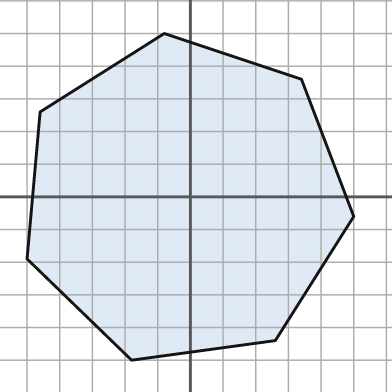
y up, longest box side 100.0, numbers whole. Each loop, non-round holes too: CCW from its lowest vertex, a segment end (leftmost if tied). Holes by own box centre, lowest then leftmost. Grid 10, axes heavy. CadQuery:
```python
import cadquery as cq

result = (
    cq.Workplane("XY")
    .moveTo(-18.0, -50.0)
    .lineTo(26.0, -44.0)
    .lineTo(50.0, -6.0)
    .lineTo(34.0, 36.0)
    .lineTo(-8.0, 50.0)
    .lineTo(-46.0, 26.0)
    .lineTo(-50.0, -19.0)
    .close()
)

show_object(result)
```